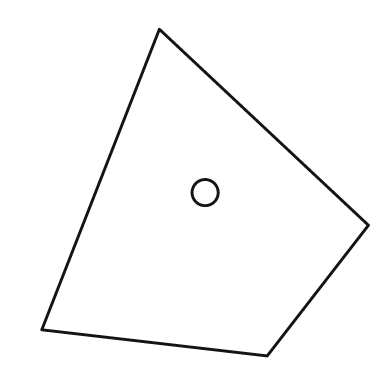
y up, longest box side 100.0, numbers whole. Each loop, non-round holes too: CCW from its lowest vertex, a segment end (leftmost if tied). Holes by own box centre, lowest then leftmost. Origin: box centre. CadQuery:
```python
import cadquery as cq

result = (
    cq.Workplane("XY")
    .moveTo(19.0, -50.0)
    .lineTo(50.0, -10.0)
    .lineTo(-14.0, 50.0)
    .lineTo(-50.0, -42.0)
    .close()
    .moveTo(0.0, 0.0)
    .circle(4.0)
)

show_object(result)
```